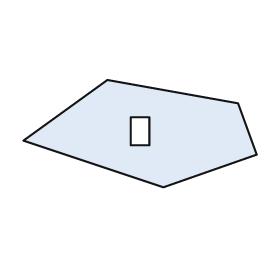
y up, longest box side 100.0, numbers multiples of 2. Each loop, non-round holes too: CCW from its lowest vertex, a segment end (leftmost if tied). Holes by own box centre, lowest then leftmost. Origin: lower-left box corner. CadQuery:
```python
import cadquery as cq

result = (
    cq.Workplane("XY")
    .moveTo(60.0, 0.0)
    .lineTo(100.0, 14.0)
    .lineTo(92.0, 36.0)
    .lineTo(36.0, 46.0)
    .lineTo(0.0, 20.0)
    .close()
    .moveTo(46.0, 18.0)
    .lineTo(54.0, 18.0)
    .lineTo(54.0, 30.0)
    .lineTo(46.0, 30.0)
    .close()
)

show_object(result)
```